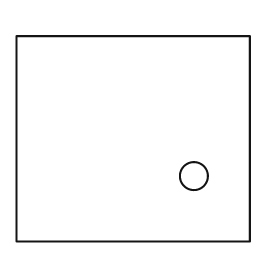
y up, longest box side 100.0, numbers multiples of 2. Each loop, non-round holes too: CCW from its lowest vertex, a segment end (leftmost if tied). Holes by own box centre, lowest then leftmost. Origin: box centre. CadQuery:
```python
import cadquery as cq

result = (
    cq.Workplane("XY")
    .moveTo(-50.0, -44.0)
    .lineTo(50.0, -44.0)
    .lineTo(50.0, 44.0)
    .lineTo(-50.0, 44.0)
    .close()
    .moveTo(26.0, -16.0)
    .circle(6.0)
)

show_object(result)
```